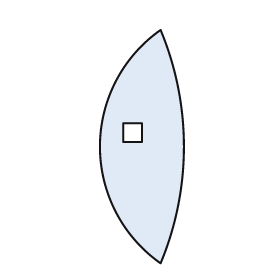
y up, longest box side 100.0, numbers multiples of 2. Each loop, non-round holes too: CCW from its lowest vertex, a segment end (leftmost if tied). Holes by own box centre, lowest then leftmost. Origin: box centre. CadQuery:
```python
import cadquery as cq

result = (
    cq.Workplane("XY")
    .moveTo(8.0, -50.0)
    .threePointArc((18.0, 0.0), (8.0, 50.0))
    .threePointArc((-18.0, 0.0), (8.0, -50.0))
    .close()
    .moveTo(-8.0, 2.0)
    .lineTo(0.0, 2.0)
    .lineTo(0.0, 10.0)
    .lineTo(-8.0, 10.0)
    .close()
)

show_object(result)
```